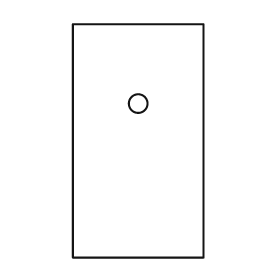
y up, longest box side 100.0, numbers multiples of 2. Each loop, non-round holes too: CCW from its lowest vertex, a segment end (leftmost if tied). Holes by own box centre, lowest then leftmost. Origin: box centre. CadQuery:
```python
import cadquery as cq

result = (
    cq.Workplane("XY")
    .moveTo(-28.0, -50.0)
    .lineTo(28.0, -50.0)
    .lineTo(28.0, 50.0)
    .lineTo(-28.0, 50.0)
    .close()
    .moveTo(0.0, 16.0)
    .circle(4.0)
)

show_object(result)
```